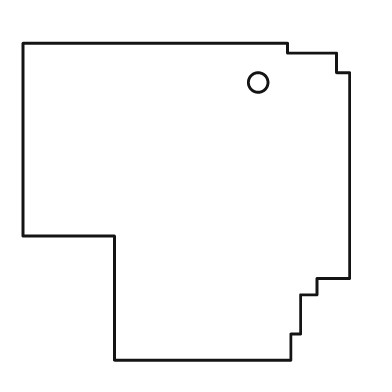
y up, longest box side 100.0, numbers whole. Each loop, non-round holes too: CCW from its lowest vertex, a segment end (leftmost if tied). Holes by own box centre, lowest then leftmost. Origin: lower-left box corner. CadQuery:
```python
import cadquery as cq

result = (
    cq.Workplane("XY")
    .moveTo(28.0, 0.0)
    .lineTo(82.0, 0.0)
    .lineTo(82.0, 8.0)
    .lineTo(85.0, 8.0)
    .lineTo(85.0, 20.0)
    .lineTo(90.0, 20.0)
    .lineTo(90.0, 25.0)
    .lineTo(100.0, 25.0)
    .lineTo(100.0, 88.0)
    .lineTo(96.0, 88.0)
    .lineTo(96.0, 94.0)
    .lineTo(81.0, 94.0)
    .lineTo(81.0, 97.0)
    .lineTo(0.0, 97.0)
    .lineTo(0.0, 38.0)
    .lineTo(28.0, 38.0)
    .close()
    .moveTo(72.0, 85.0)
    .circle(3.0)
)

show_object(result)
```